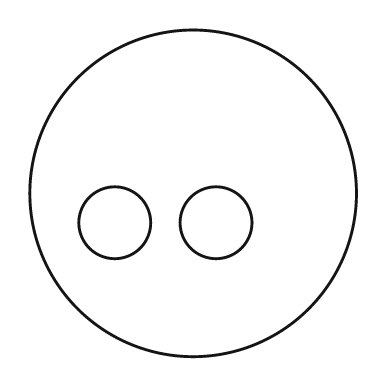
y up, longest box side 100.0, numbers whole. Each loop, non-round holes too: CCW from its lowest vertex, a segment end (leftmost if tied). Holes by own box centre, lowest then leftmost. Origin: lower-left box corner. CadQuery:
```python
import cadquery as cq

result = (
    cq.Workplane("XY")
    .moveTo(50.0, 50.0)
    .circle(50.0)
    .moveTo(26.0, 41.0)
    .circle(11.0)
    .moveTo(57.0, 41.0)
    .circle(11.0)
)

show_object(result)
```